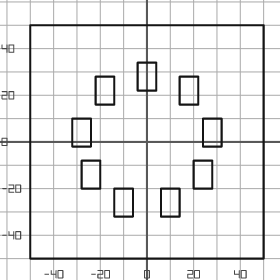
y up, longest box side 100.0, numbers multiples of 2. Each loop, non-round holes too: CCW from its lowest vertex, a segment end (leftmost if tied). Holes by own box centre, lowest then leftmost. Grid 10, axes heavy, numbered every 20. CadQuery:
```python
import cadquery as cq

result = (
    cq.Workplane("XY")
    .moveTo(-50.0, -50.0)
    .lineTo(50.0, -50.0)
    .lineTo(50.0, 50.0)
    .lineTo(-50.0, 50.0)
    .close()
    .moveTo(-14.0, -32.0)
    .lineTo(-6.0, -32.0)
    .lineTo(-6.0, -20.0)
    .lineTo(-14.0, -20.0)
    .close()
    .moveTo(6.0, -32.0)
    .lineTo(14.0, -32.0)
    .lineTo(14.0, -20.0)
    .lineTo(6.0, -20.0)
    .close()
    .moveTo(-28.0, -20.0)
    .lineTo(-20.0, -20.0)
    .lineTo(-20.0, -8.0)
    .lineTo(-28.0, -8.0)
    .close()
    .moveTo(20.0, -20.0)
    .lineTo(28.0, -20.0)
    .lineTo(28.0, -8.0)
    .lineTo(20.0, -8.0)
    .close()
    .moveTo(-32.0, -2.0)
    .lineTo(-24.0, -2.0)
    .lineTo(-24.0, 10.0)
    .lineTo(-32.0, 10.0)
    .close()
    .moveTo(24.0, -2.0)
    .lineTo(32.0, -2.0)
    .lineTo(32.0, 10.0)
    .lineTo(24.0, 10.0)
    .close()
    .moveTo(-22.0, 16.0)
    .lineTo(-14.0, 16.0)
    .lineTo(-14.0, 28.0)
    .lineTo(-22.0, 28.0)
    .close()
    .moveTo(14.0, 16.0)
    .lineTo(22.0, 16.0)
    .lineTo(22.0, 28.0)
    .lineTo(14.0, 28.0)
    .close()
    .moveTo(-4.0, 22.0)
    .lineTo(4.0, 22.0)
    .lineTo(4.0, 34.0)
    .lineTo(-4.0, 34.0)
    .close()
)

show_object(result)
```